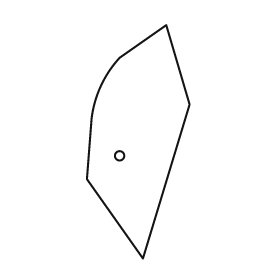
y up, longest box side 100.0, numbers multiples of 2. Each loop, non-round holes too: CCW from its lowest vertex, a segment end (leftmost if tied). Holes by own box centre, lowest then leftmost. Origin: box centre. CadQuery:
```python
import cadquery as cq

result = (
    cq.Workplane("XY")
    .moveTo(2.0, -50.0)
    .lineTo(22.0, 16.0)
    .lineTo(12.0, 50.0)
    .lineTo(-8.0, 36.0)
    .threePointArc((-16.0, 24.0), (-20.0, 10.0))
    .lineTo(-22.0, -16.0)
    .close()
    .moveTo(-8.0, -6.0)
    .circle(2.0)
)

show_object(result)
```